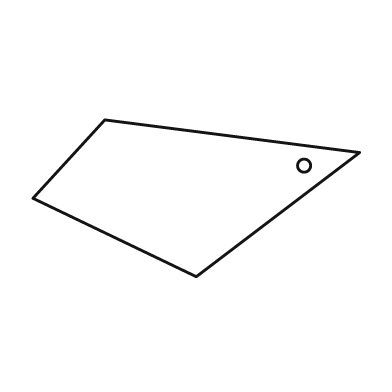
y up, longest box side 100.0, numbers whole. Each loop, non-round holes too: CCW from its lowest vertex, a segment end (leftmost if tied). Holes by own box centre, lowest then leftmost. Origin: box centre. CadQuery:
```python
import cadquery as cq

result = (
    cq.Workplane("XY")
    .moveTo(0.0, -24.0)
    .lineTo(50.0, 14.0)
    .lineTo(-28.0, 24.0)
    .lineTo(-50.0, 0.0)
    .close()
    .moveTo(33.0, 10.0)
    .circle(2.0)
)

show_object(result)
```